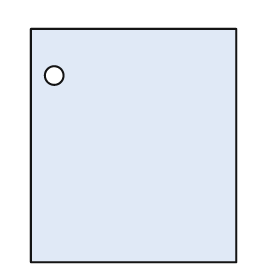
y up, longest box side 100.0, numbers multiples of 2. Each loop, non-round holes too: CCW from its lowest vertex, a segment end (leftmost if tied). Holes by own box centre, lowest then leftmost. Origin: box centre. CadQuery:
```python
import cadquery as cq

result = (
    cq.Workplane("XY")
    .moveTo(-44.0, -50.0)
    .lineTo(44.0, -50.0)
    .lineTo(44.0, 50.0)
    .lineTo(-44.0, 50.0)
    .close()
    .moveTo(-34.0, 30.0)
    .circle(4.0)
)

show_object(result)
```